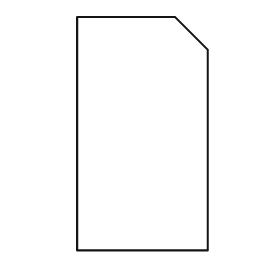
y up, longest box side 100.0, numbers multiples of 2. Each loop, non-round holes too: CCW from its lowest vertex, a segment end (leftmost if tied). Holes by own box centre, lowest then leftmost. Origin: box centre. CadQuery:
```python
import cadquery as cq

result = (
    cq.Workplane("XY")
    .moveTo(-28.0, -50.0)
    .lineTo(28.0, -50.0)
    .lineTo(28.0, 36.0)
    .lineTo(14.0, 50.0)
    .lineTo(-28.0, 50.0)
    .close()
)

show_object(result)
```